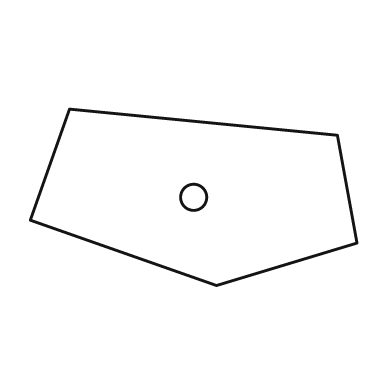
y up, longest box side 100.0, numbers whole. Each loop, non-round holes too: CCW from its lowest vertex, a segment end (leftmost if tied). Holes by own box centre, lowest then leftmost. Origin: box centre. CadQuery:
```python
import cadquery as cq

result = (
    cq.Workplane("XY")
    .moveTo(7.0, -27.0)
    .lineTo(50.0, -14.0)
    .lineTo(44.0, 19.0)
    .lineTo(-38.0, 27.0)
    .lineTo(-50.0, -7.0)
    .close()
    .moveTo(0.0, 0.0)
    .circle(4.0)
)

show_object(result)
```